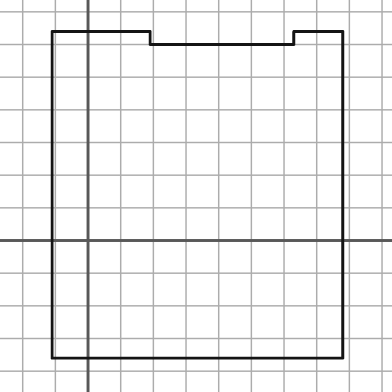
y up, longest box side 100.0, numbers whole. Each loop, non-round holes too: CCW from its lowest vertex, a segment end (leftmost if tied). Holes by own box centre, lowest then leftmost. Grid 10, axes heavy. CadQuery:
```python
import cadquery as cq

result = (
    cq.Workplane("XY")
    .moveTo(-11.0, -36.0)
    .lineTo(78.0, -36.0)
    .lineTo(78.0, 64.0)
    .lineTo(63.0, 64.0)
    .lineTo(63.0, 60.0)
    .lineTo(19.0, 60.0)
    .lineTo(19.0, 64.0)
    .lineTo(-11.0, 64.0)
    .close()
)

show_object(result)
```